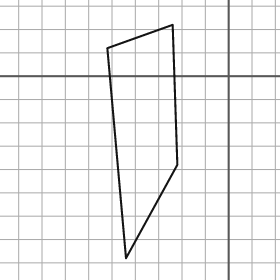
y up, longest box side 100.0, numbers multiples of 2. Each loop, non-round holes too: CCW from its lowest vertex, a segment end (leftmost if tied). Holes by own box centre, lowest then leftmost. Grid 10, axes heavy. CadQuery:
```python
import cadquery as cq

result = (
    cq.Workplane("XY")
    .moveTo(-44.0, -78.0)
    .lineTo(-22.0, -38.0)
    .lineTo(-24.0, 22.0)
    .lineTo(-52.0, 12.0)
    .close()
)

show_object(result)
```